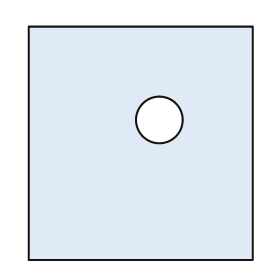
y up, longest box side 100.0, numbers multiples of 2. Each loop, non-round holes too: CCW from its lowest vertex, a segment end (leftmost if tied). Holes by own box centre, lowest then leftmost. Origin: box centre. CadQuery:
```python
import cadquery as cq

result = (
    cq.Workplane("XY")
    .moveTo(-48.0, -50.0)
    .lineTo(48.0, -50.0)
    .lineTo(48.0, 50.0)
    .lineTo(-48.0, 50.0)
    .close()
    .moveTo(8.0, 10.0)
    .circle(10.0)
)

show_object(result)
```